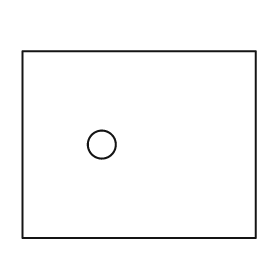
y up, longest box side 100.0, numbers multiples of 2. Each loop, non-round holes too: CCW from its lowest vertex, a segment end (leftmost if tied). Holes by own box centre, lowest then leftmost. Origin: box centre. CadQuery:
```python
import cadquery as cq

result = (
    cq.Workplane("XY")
    .moveTo(-50.0, -40.0)
    .lineTo(50.0, -40.0)
    .lineTo(50.0, 40.0)
    .lineTo(-50.0, 40.0)
    .close()
    .moveTo(-16.0, 0.0)
    .circle(6.0)
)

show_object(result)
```